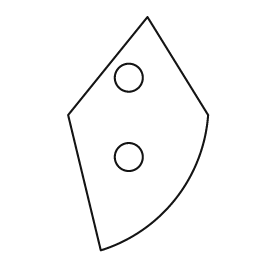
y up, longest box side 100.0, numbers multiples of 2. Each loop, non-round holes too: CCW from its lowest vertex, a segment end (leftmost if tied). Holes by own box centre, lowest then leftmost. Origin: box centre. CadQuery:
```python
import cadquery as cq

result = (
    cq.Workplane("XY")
    .moveTo(-16.0, -50.0)
    .threePointArc((16.0, -28.0), (30.0, 8.0))
    .lineTo(4.0, 50.0)
    .lineTo(-30.0, 8.0)
    .close()
    .moveTo(-4.0, -10.0)
    .circle(6.0)
    .moveTo(-4.0, 24.0)
    .circle(6.0)
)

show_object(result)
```